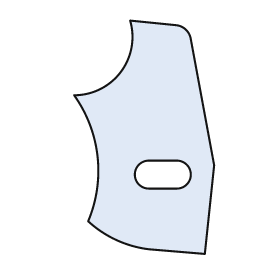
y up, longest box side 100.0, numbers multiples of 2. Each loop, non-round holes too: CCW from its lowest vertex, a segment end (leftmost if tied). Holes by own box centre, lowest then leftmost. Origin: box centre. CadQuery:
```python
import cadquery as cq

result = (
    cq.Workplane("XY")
    .moveTo(26.0, -50.0)
    .lineTo(30.0, -12.0)
    .lineTo(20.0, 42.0)
    .threePointArc((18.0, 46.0), (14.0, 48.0))
    .lineTo(-6.0, 50.0)
    .threePointArc((-10.0, 28.0), (-30.0, 18.0))
    .threePointArc((-20.0, -8.0), (-24.0, -36.0))
    .threePointArc((-12.0, -44.0), (2.0, -48.0))
    .close()
    .moveTo(2.0, -22.0)
    .lineTo(14.0, -22.0)
    .threePointArc((20.0, -16.0), (14.0, -10.0))
    .lineTo(2.0, -10.0)
    .threePointArc((-4.0, -16.0), (2.0, -22.0))
    .close()
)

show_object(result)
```